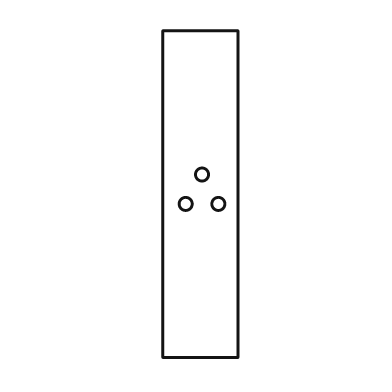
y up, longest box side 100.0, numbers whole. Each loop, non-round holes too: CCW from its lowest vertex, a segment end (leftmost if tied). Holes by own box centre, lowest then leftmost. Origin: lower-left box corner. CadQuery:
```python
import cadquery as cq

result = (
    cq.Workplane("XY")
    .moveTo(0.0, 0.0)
    .lineTo(23.0, 0.0)
    .lineTo(23.0, 100.0)
    .lineTo(0.0, 100.0)
    .close()
    .moveTo(7.0, 47.0)
    .circle(2.0)
    .moveTo(17.0, 47.0)
    .circle(2.0)
    .moveTo(12.0, 56.0)
    .circle(2.0)
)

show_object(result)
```